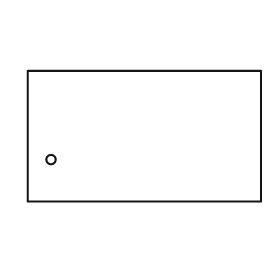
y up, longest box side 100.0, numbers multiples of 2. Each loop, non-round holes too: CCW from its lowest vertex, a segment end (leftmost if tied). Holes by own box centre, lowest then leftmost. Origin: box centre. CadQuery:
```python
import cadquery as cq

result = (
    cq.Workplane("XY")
    .moveTo(-50.0, -28.0)
    .lineTo(50.0, -28.0)
    .lineTo(50.0, 28.0)
    .lineTo(-50.0, 28.0)
    .close()
    .moveTo(-40.0, -10.0)
    .circle(2.0)
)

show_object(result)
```